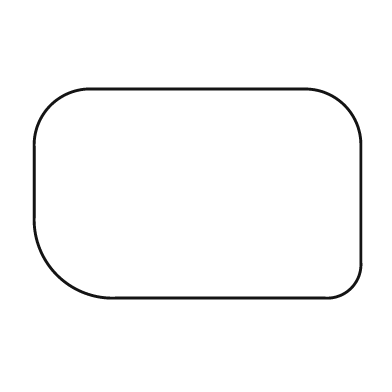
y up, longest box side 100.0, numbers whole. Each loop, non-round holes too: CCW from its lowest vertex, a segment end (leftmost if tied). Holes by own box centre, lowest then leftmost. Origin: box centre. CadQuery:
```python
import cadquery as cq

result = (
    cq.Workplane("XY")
    .moveTo(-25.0, -32.0)
    .lineTo(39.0, -32.0)
    .threePointArc((47.0, -29.0), (50.0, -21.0))
    .lineTo(50.0, 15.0)
    .threePointArc((45.0, 27.0), (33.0, 32.0))
    .lineTo(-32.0, 32.0)
    .threePointArc((-45.0, 27.0), (-50.0, 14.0))
    .lineTo(-50.0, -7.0)
    .threePointArc((-43.0, -25.0), (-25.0, -32.0))
    .close()
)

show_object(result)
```